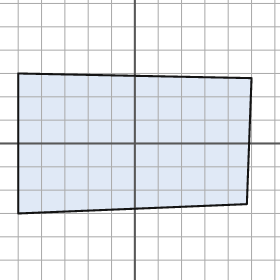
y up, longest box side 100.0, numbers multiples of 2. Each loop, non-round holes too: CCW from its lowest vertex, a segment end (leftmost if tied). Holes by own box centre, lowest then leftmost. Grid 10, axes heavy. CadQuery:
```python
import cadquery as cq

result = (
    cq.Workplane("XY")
    .moveTo(-50.0, -30.0)
    .lineTo(48.0, -26.0)
    .lineTo(50.0, 28.0)
    .lineTo(-50.0, 30.0)
    .close()
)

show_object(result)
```